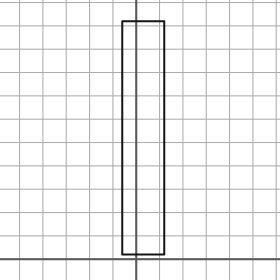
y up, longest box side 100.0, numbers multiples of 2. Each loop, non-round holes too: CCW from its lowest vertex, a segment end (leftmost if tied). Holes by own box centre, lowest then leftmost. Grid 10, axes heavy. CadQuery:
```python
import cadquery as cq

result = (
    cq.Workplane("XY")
    .moveTo(-6.0, 2.0)
    .lineTo(12.0, 2.0)
    .lineTo(12.0, 102.0)
    .lineTo(-6.0, 102.0)
    .close()
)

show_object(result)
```